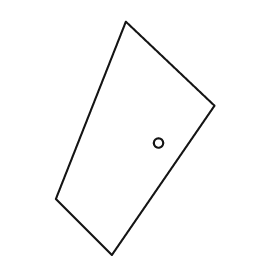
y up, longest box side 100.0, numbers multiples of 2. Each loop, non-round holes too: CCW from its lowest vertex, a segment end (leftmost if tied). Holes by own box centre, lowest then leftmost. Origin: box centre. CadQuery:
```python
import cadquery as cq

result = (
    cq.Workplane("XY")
    .moveTo(-10.0, -50.0)
    .lineTo(34.0, 14.0)
    .lineTo(-4.0, 50.0)
    .lineTo(-34.0, -26.0)
    .close()
    .moveTo(10.0, -2.0)
    .circle(2.0)
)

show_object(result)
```